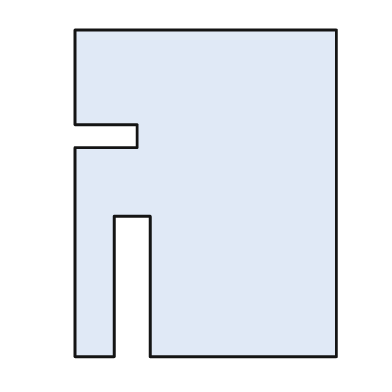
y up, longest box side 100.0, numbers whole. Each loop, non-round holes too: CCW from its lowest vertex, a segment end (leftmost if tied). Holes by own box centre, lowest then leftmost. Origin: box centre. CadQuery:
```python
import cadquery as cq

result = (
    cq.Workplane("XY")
    .moveTo(-40.0, -50.0)
    .lineTo(-28.0, -50.0)
    .lineTo(-28.0, -7.0)
    .lineTo(-17.0, -7.0)
    .lineTo(-17.0, -50.0)
    .lineTo(40.0, -50.0)
    .lineTo(40.0, 50.0)
    .lineTo(-40.0, 50.0)
    .lineTo(-40.0, 21.0)
    .lineTo(-21.0, 21.0)
    .lineTo(-21.0, 14.0)
    .lineTo(-40.0, 14.0)
    .close()
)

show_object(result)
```